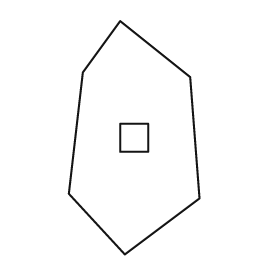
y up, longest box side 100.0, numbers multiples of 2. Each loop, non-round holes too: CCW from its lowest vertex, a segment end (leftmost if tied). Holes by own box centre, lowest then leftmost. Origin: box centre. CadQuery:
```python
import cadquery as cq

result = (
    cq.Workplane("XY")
    .moveTo(-4.0, -50.0)
    .lineTo(28.0, -26.0)
    .lineTo(24.0, 26.0)
    .lineTo(-6.0, 50.0)
    .lineTo(-22.0, 28.0)
    .lineTo(-28.0, -24.0)
    .close()
    .moveTo(-6.0, -6.0)
    .lineTo(6.0, -6.0)
    .lineTo(6.0, 6.0)
    .lineTo(-6.0, 6.0)
    .close()
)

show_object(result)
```